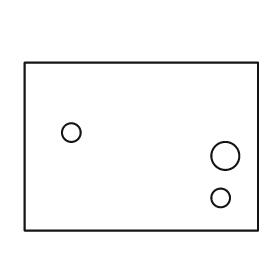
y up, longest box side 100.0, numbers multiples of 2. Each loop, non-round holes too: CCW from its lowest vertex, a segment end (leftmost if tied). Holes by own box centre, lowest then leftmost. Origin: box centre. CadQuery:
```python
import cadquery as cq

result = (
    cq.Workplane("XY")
    .moveTo(-50.0, -36.0)
    .lineTo(50.0, -36.0)
    .lineTo(50.0, 36.0)
    .lineTo(-50.0, 36.0)
    .close()
    .moveTo(34.0, -22.0)
    .circle(4.0)
    .moveTo(36.0, -4.0)
    .circle(6.0)
    .moveTo(-30.0, 6.0)
    .circle(4.0)
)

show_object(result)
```